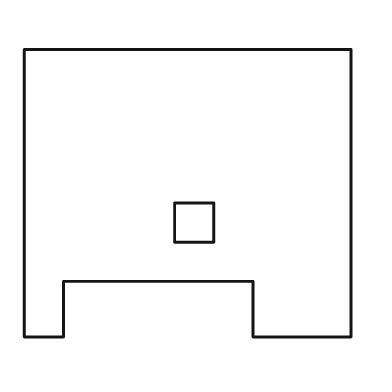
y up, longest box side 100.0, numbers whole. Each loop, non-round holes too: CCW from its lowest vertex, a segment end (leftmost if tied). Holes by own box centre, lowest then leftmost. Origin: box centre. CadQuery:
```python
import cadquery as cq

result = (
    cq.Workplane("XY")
    .moveTo(-50.0, -44.0)
    .lineTo(-38.0, -44.0)
    .lineTo(-38.0, -27.0)
    .lineTo(20.0, -27.0)
    .lineTo(20.0, -44.0)
    .lineTo(50.0, -44.0)
    .lineTo(50.0, 44.0)
    .lineTo(-50.0, 44.0)
    .close()
    .moveTo(-4.0, -15.0)
    .lineTo(8.0, -15.0)
    .lineTo(8.0, -3.0)
    .lineTo(-4.0, -3.0)
    .close()
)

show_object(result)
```